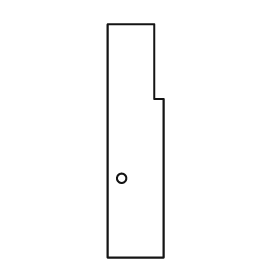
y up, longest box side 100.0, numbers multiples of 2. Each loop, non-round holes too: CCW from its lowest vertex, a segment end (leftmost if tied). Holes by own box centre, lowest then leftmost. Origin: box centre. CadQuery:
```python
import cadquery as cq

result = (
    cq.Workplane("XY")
    .moveTo(-12.0, -50.0)
    .lineTo(12.0, -50.0)
    .lineTo(12.0, 18.0)
    .lineTo(8.0, 18.0)
    .lineTo(8.0, 50.0)
    .lineTo(-12.0, 50.0)
    .close()
    .moveTo(-6.0, -16.0)
    .circle(2.0)
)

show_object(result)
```